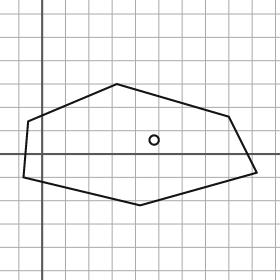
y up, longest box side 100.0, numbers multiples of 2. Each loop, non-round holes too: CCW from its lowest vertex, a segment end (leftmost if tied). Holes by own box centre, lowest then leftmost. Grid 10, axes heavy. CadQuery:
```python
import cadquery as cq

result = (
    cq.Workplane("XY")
    .moveTo(42.0, -22.0)
    .lineTo(92.0, -8.0)
    .lineTo(80.0, 16.0)
    .lineTo(32.0, 30.0)
    .lineTo(-6.0, 14.0)
    .lineTo(-8.0, -10.0)
    .close()
    .moveTo(48.0, 6.0)
    .circle(2.0)
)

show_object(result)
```